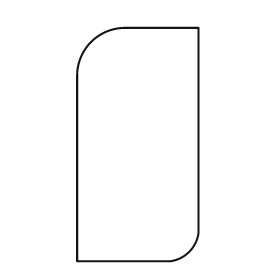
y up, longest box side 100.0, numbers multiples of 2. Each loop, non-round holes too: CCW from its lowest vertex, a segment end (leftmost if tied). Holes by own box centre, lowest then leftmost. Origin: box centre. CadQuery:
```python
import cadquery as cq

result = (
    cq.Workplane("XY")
    .moveTo(-26.0, -50.0)
    .lineTo(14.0, -50.0)
    .threePointArc((22.0, -46.0), (26.0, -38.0))
    .lineTo(26.0, 50.0)
    .lineTo(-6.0, 50.0)
    .threePointArc((-20.0, 44.0), (-26.0, 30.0))
    .close()
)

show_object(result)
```